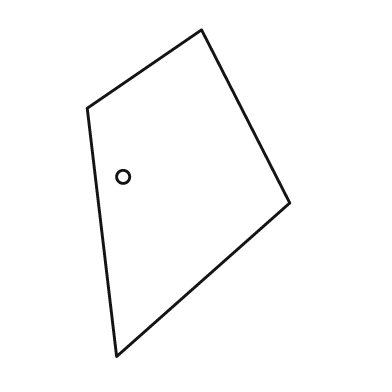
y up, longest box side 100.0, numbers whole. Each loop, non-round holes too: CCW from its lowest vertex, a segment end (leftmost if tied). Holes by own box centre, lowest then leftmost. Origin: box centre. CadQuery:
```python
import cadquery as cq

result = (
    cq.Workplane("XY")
    .moveTo(-22.0, -50.0)
    .lineTo(31.0, -3.0)
    .lineTo(4.0, 50.0)
    .lineTo(-31.0, 26.0)
    .close()
    .moveTo(-20.0, 5.0)
    .circle(2.0)
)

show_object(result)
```